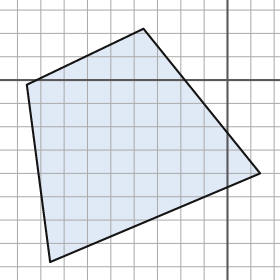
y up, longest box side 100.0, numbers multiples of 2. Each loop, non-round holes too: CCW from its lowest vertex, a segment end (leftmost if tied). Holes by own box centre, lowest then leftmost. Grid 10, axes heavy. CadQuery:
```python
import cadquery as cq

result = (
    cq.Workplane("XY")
    .moveTo(-76.0, -78.0)
    .lineTo(14.0, -40.0)
    .lineTo(-36.0, 22.0)
    .lineTo(-86.0, -2.0)
    .close()
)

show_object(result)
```